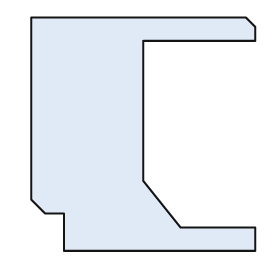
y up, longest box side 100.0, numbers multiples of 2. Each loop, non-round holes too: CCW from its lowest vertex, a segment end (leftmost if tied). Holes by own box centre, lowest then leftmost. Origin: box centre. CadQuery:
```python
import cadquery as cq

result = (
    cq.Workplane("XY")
    .moveTo(-34.0, -50.0)
    .lineTo(48.0, -50.0)
    .lineTo(48.0, -40.0)
    .lineTo(16.0, -40.0)
    .lineTo(0.0, -20.0)
    .lineTo(0.0, 40.0)
    .lineTo(48.0, 40.0)
    .lineTo(48.0, 46.0)
    .lineTo(44.0, 50.0)
    .lineTo(-48.0, 50.0)
    .lineTo(-48.0, -28.0)
    .lineTo(-42.0, -34.0)
    .lineTo(-34.0, -34.0)
    .close()
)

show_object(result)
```